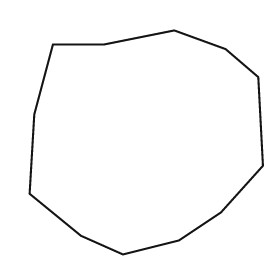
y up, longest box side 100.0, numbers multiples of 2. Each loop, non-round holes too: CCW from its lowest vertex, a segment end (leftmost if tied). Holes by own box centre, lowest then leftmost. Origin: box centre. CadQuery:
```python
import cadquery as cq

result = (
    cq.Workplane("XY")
    .moveTo(-10.0, -48.0)
    .lineTo(14.0, -42.0)
    .lineTo(32.0, -30.0)
    .lineTo(50.0, -10.0)
    .lineTo(48.0, 28.0)
    .lineTo(34.0, 40.0)
    .lineTo(12.0, 48.0)
    .lineTo(-18.0, 42.0)
    .lineTo(-40.0, 42.0)
    .lineTo(-48.0, 12.0)
    .lineTo(-50.0, -22.0)
    .lineTo(-28.0, -40.0)
    .close()
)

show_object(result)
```